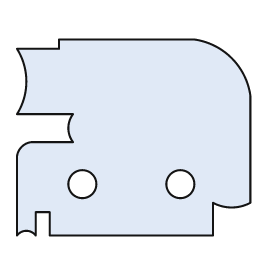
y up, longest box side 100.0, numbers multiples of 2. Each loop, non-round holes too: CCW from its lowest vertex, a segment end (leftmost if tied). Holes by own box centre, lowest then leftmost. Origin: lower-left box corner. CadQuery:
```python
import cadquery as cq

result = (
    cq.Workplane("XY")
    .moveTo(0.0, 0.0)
    .threePointArc((4.0, 2.0), (8.0, 0.0))
    .lineTo(8.0, 10.0)
    .lineTo(14.0, 10.0)
    .lineTo(14.0, 0.0)
    .lineTo(84.0, 0.0)
    .lineTo(84.0, 14.0)
    .threePointArc((92.0, 12.0), (100.0, 14.0))
    .lineTo(100.0, 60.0)
    .threePointArc((92.0, 76.0), (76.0, 84.0))
    .lineTo(18.0, 84.0)
    .lineTo(18.0, 80.0)
    .lineTo(0.0, 80.0)
    .threePointArc((4.0, 66.0), (0.0, 52.0))
    .lineTo(24.0, 52.0)
    .threePointArc((22.0, 46.0), (24.0, 40.0))
    .lineTo(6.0, 40.0)
    .threePointArc((2.0, 38.0), (0.0, 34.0))
    .close()
    .moveTo(28.0, 22.0)
    .circle(6.0)
    .moveTo(70.0, 22.0)
    .circle(6.0)
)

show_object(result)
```